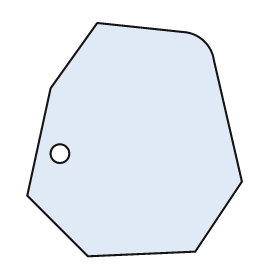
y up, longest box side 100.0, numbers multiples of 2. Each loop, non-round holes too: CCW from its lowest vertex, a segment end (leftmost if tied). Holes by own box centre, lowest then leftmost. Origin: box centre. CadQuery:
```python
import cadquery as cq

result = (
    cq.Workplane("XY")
    .moveTo(-20.0, -50.0)
    .lineTo(26.0, -48.0)
    .lineTo(46.0, -18.0)
    .lineTo(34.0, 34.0)
    .threePointArc((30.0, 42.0), (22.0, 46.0))
    .lineTo(-16.0, 50.0)
    .lineTo(-36.0, 22.0)
    .lineTo(-46.0, -24.0)
    .close()
    .moveTo(-32.0, -6.0)
    .circle(4.0)
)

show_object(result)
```